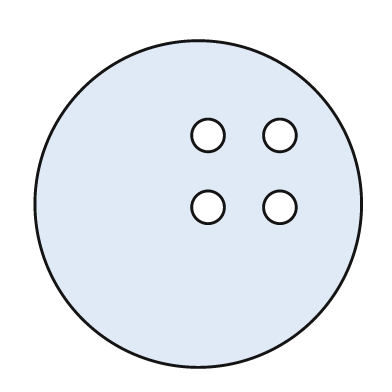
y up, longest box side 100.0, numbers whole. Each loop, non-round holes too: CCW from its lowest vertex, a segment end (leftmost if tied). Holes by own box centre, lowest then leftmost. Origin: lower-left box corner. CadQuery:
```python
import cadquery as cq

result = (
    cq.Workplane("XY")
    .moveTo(50.0, 50.0)
    .circle(50.0)
    .moveTo(53.0, 49.0)
    .circle(5.0)
    .moveTo(75.0, 49.0)
    .circle(5.0)
    .moveTo(53.0, 71.0)
    .circle(5.0)
    .moveTo(75.0, 71.0)
    .circle(5.0)
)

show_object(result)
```